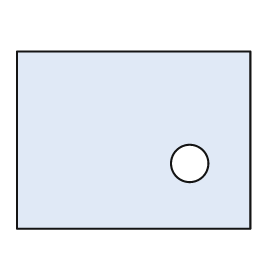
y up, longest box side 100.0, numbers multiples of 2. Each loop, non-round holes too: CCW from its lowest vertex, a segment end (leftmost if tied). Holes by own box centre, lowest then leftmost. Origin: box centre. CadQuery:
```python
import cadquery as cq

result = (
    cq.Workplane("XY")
    .moveTo(-50.0, -38.0)
    .lineTo(50.0, -38.0)
    .lineTo(50.0, 38.0)
    .lineTo(-50.0, 38.0)
    .close()
    .moveTo(24.0, -10.0)
    .circle(8.0)
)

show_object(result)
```